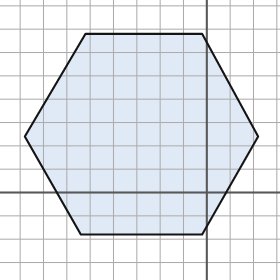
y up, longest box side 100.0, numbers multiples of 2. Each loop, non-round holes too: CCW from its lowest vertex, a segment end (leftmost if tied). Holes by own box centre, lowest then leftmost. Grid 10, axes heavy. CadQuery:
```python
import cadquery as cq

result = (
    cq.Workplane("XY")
    .moveTo(-54.0, -18.0)
    .lineTo(-2.0, -18.0)
    .lineTo(22.0, 24.0)
    .lineTo(-2.0, 68.0)
    .lineTo(-52.0, 68.0)
    .lineTo(-78.0, 24.0)
    .close()
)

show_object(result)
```